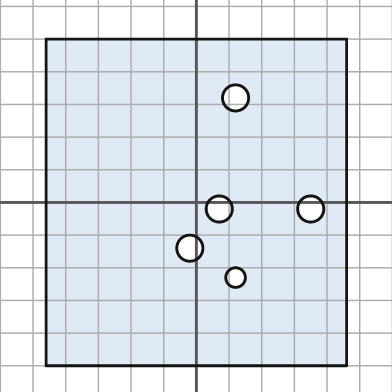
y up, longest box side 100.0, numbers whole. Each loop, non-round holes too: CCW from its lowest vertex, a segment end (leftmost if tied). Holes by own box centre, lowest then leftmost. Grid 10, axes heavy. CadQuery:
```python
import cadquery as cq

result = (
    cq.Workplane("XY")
    .moveTo(-46.0, -50.0)
    .lineTo(46.0, -50.0)
    .lineTo(46.0, 50.0)
    .lineTo(-46.0, 50.0)
    .close()
    .moveTo(12.0, -23.0)
    .circle(3.0)
    .moveTo(-2.0, -14.0)
    .circle(4.0)
    .moveTo(7.0, -2.0)
    .circle(4.0)
    .moveTo(35.0, -2.0)
    .circle(4.0)
    .moveTo(12.0, 32.0)
    .circle(4.0)
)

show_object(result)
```